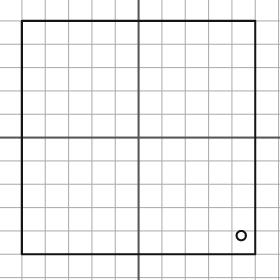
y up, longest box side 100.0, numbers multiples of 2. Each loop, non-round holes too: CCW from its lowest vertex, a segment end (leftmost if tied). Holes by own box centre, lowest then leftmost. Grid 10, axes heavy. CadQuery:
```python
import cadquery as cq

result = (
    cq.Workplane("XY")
    .moveTo(-50.0, -50.0)
    .lineTo(50.0, -50.0)
    .lineTo(50.0, 50.0)
    .lineTo(-50.0, 50.0)
    .close()
    .moveTo(44.0, -42.0)
    .circle(2.0)
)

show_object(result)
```